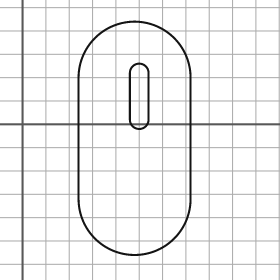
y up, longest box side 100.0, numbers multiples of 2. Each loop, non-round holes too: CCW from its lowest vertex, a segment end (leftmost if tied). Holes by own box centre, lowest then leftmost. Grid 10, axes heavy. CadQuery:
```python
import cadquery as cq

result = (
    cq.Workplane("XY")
    .moveTo(24.0, -32.0)
    .threePointArc((48.0, -56.0), (72.0, -32.0))
    .lineTo(72.0, 20.0)
    .threePointArc((48.0, 44.0), (24.0, 20.0))
    .close()
    .moveTo(46.0, 2.0)
    .threePointArc((50.0, -2.0), (54.0, 2.0))
    .lineTo(54.0, 22.0)
    .threePointArc((50.0, 26.0), (46.0, 22.0))
    .close()
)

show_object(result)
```